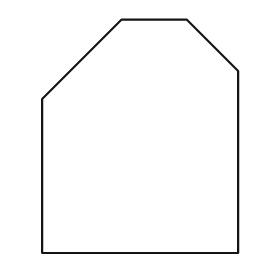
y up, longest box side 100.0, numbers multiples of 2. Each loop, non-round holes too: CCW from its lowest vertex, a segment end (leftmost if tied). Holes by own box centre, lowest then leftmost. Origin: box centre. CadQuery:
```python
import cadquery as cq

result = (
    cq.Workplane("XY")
    .moveTo(-42.0, -50.0)
    .lineTo(42.0, -50.0)
    .lineTo(42.0, 28.0)
    .lineTo(20.0, 50.0)
    .lineTo(-8.0, 50.0)
    .lineTo(-42.0, 16.0)
    .close()
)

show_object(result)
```